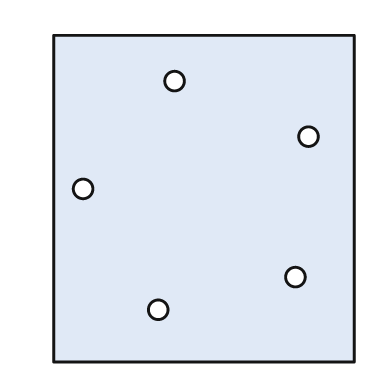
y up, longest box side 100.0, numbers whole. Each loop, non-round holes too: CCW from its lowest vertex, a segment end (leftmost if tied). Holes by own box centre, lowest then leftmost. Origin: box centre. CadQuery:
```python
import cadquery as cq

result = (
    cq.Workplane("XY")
    .moveTo(-46.0, -50.0)
    .lineTo(46.0, -50.0)
    .lineTo(46.0, 50.0)
    .lineTo(-46.0, 50.0)
    .close()
    .moveTo(-14.0, -34.0)
    .circle(3.0)
    .moveTo(28.0, -24.0)
    .circle(3.0)
    .moveTo(-37.0, 3.0)
    .circle(3.0)
    .moveTo(32.0, 19.0)
    .circle(3.0)
    .moveTo(-9.0, 36.0)
    .circle(3.0)
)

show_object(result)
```